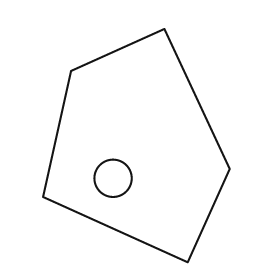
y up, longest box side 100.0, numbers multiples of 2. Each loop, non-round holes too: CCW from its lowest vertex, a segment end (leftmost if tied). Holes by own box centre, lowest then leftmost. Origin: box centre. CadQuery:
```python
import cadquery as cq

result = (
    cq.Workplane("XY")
    .moveTo(22.0, -50.0)
    .lineTo(40.0, -10.0)
    .lineTo(12.0, 50.0)
    .lineTo(-28.0, 32.0)
    .lineTo(-40.0, -22.0)
    .close()
    .moveTo(-10.0, -14.0)
    .circle(8.0)
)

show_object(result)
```